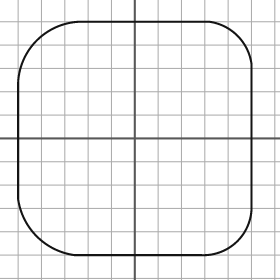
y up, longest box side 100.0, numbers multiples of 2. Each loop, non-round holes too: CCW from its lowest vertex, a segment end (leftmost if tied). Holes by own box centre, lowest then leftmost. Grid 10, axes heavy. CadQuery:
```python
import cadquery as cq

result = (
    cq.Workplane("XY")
    .moveTo(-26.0, -50.0)
    .lineTo(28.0, -50.0)
    .threePointArc((44.0, -44.0), (50.0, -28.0))
    .lineTo(50.0, 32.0)
    .threePointArc((44.0, 44.0), (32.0, 50.0))
    .lineTo(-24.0, 50.0)
    .threePointArc((-42.0, 42.0), (-50.0, 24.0))
    .lineTo(-50.0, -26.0)
    .threePointArc((-42.0, -42.0), (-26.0, -50.0))
    .close()
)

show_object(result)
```